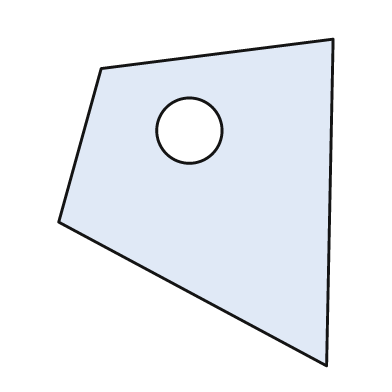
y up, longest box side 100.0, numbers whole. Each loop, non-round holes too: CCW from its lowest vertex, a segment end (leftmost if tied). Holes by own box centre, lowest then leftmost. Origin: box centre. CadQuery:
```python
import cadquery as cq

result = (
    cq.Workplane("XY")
    .moveTo(40.0, -50.0)
    .lineTo(42.0, 50.0)
    .lineTo(-29.0, 41.0)
    .lineTo(-42.0, -6.0)
    .close()
    .moveTo(-2.0, 22.0)
    .circle(10.0)
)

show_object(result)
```